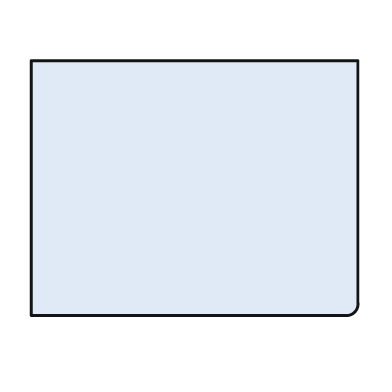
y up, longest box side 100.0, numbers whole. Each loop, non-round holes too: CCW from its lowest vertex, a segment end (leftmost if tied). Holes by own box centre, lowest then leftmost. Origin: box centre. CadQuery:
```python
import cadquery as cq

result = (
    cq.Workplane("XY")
    .moveTo(-50.0, -39.0)
    .lineTo(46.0, -39.0)
    .threePointArc((49.0, -38.0), (50.0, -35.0))
    .lineTo(50.0, 39.0)
    .lineTo(-50.0, 39.0)
    .close()
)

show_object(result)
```